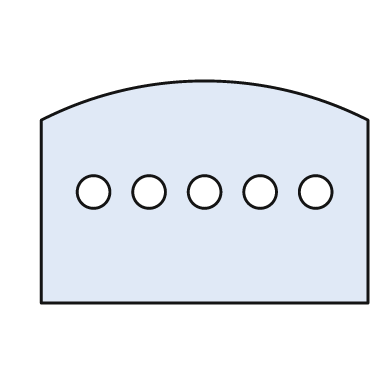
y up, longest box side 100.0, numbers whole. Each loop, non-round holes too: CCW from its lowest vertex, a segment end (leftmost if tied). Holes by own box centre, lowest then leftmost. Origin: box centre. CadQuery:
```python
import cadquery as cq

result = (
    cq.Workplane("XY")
    .moveTo(-50.0, -34.0)
    .lineTo(50.0, -34.0)
    .lineTo(50.0, 22.0)
    .threePointArc((0.0, 34.0), (-50.0, 22.0))
    .close()
    .moveTo(-34.0, 0.0)
    .circle(5.0)
    .moveTo(-17.0, 0.0)
    .circle(5.0)
    .moveTo(0.0, 0.0)
    .circle(5.0)
    .moveTo(17.0, 0.0)
    .circle(5.0)
    .moveTo(34.0, 0.0)
    .circle(5.0)
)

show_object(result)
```